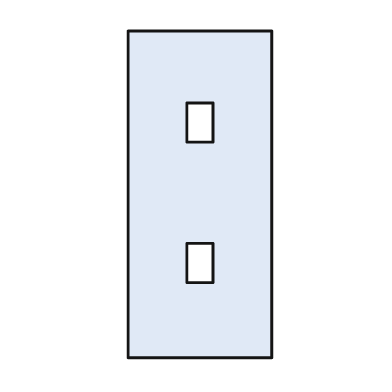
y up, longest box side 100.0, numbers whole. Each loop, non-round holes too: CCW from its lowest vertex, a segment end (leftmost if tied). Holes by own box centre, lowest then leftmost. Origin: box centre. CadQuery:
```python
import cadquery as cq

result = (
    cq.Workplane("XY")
    .moveTo(-22.0, -50.0)
    .lineTo(22.0, -50.0)
    .lineTo(22.0, 50.0)
    .lineTo(-22.0, 50.0)
    .close()
    .moveTo(-4.0, -27.0)
    .lineTo(4.0, -27.0)
    .lineTo(4.0, -15.0)
    .lineTo(-4.0, -15.0)
    .close()
    .moveTo(-4.0, 16.0)
    .lineTo(4.0, 16.0)
    .lineTo(4.0, 28.0)
    .lineTo(-4.0, 28.0)
    .close()
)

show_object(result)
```